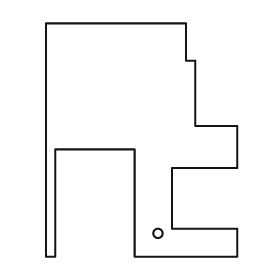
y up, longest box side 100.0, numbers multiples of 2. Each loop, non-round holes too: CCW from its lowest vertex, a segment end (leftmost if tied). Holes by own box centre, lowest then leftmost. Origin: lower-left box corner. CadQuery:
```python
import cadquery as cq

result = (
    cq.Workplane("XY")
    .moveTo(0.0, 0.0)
    .lineTo(4.0, 0.0)
    .lineTo(4.0, 46.0)
    .lineTo(38.0, 46.0)
    .lineTo(38.0, 0.0)
    .lineTo(82.0, 0.0)
    .lineTo(82.0, 12.0)
    .lineTo(54.0, 12.0)
    .lineTo(54.0, 38.0)
    .lineTo(82.0, 38.0)
    .lineTo(82.0, 56.0)
    .lineTo(64.0, 56.0)
    .lineTo(64.0, 84.0)
    .lineTo(60.0, 84.0)
    .lineTo(60.0, 100.0)
    .lineTo(0.0, 100.0)
    .close()
    .moveTo(48.0, 10.0)
    .circle(2.0)
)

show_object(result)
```